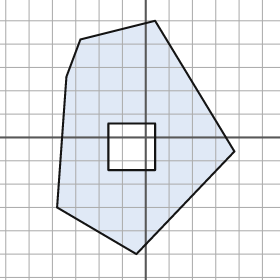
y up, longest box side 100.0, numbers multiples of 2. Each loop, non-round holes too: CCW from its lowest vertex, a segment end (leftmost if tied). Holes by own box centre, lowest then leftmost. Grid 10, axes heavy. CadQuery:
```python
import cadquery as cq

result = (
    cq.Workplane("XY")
    .moveTo(-4.0, -50.0)
    .lineTo(38.0, -6.0)
    .lineTo(4.0, 50.0)
    .lineTo(-28.0, 42.0)
    .lineTo(-34.0, 26.0)
    .lineTo(-38.0, -30.0)
    .close()
    .moveTo(-16.0, -14.0)
    .lineTo(4.0, -14.0)
    .lineTo(4.0, 6.0)
    .lineTo(-16.0, 6.0)
    .close()
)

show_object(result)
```